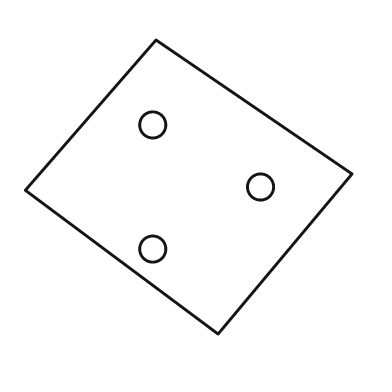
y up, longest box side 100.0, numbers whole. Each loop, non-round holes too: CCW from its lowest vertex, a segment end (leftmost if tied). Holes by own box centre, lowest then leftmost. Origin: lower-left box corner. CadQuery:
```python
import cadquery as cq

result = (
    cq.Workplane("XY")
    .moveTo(59.0, 0.0)
    .lineTo(100.0, 49.0)
    .lineTo(40.0, 90.0)
    .lineTo(0.0, 44.0)
    .close()
    .moveTo(39.0, 26.0)
    .circle(4.0)
    .moveTo(72.0, 45.0)
    .circle(4.0)
    .moveTo(39.0, 64.0)
    .circle(4.0)
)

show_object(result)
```